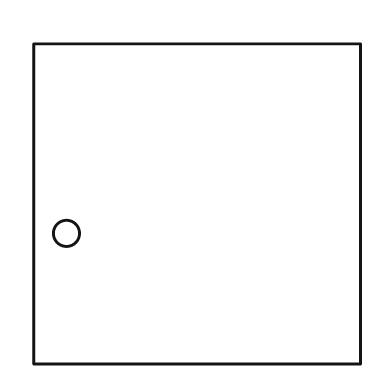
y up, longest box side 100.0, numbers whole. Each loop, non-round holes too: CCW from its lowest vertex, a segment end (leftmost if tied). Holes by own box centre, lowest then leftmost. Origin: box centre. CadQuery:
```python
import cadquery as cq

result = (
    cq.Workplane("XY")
    .moveTo(-50.0, -49.0)
    .lineTo(50.0, -49.0)
    .lineTo(50.0, 49.0)
    .lineTo(-50.0, 49.0)
    .close()
    .moveTo(-40.0, -9.0)
    .circle(4.0)
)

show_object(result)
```